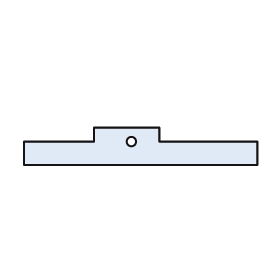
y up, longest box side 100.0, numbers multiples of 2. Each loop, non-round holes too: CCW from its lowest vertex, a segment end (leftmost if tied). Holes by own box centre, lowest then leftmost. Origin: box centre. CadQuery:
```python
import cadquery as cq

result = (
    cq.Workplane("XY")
    .moveTo(-50.0, -8.0)
    .lineTo(50.0, -8.0)
    .lineTo(50.0, 2.0)
    .lineTo(8.0, 2.0)
    .lineTo(8.0, 8.0)
    .lineTo(-20.0, 8.0)
    .lineTo(-20.0, 2.0)
    .lineTo(-50.0, 2.0)
    .close()
    .moveTo(-4.0, 2.0)
    .circle(2.0)
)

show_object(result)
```